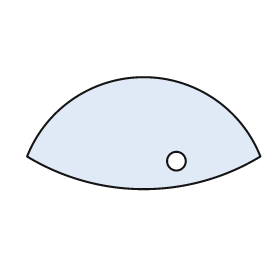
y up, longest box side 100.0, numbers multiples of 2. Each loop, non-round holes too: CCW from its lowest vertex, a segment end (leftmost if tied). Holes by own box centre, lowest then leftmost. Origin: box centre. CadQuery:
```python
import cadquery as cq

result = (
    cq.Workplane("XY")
    .moveTo(-50.0, -10.0)
    .threePointArc((0.0, -24.0), (50.0, -10.0))
    .threePointArc((0.0, 24.0), (-50.0, -10.0))
    .close()
    .moveTo(14.0, -12.0)
    .circle(4.0)
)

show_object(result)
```